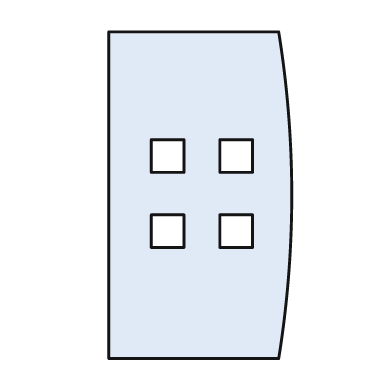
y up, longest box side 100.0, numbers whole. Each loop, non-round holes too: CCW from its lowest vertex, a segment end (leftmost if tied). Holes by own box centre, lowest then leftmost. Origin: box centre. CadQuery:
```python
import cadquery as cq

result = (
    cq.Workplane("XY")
    .moveTo(-28.0, -50.0)
    .lineTo(24.0, -50.0)
    .threePointArc((28.0, 0.0), (24.0, 50.0))
    .lineTo(-28.0, 50.0)
    .close()
    .moveTo(-15.0, -16.0)
    .lineTo(-5.0, -16.0)
    .lineTo(-5.0, -6.0)
    .lineTo(-15.0, -6.0)
    .close()
    .moveTo(6.0, -16.0)
    .lineTo(16.0, -16.0)
    .lineTo(16.0, -6.0)
    .lineTo(6.0, -6.0)
    .close()
    .moveTo(-15.0, 7.0)
    .lineTo(-5.0, 7.0)
    .lineTo(-5.0, 17.0)
    .lineTo(-15.0, 17.0)
    .close()
    .moveTo(6.0, 7.0)
    .lineTo(16.0, 7.0)
    .lineTo(16.0, 17.0)
    .lineTo(6.0, 17.0)
    .close()
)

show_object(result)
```